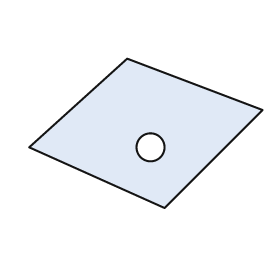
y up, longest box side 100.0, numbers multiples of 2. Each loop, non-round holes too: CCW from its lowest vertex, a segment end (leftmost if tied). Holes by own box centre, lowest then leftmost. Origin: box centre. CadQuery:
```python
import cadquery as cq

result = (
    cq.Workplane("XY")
    .moveTo(8.0, -32.0)
    .lineTo(50.0, 10.0)
    .lineTo(-8.0, 32.0)
    .lineTo(-50.0, -6.0)
    .close()
    .moveTo(2.0, -6.0)
    .circle(6.0)
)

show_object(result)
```